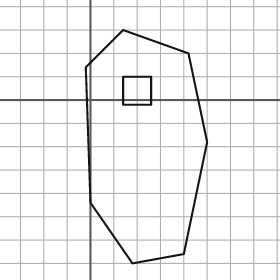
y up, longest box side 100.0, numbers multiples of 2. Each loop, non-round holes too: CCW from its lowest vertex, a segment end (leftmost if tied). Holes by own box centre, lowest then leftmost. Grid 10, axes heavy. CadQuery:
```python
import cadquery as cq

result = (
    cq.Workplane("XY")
    .moveTo(18.0, -70.0)
    .lineTo(40.0, -66.0)
    .lineTo(50.0, -18.0)
    .lineTo(42.0, 20.0)
    .lineTo(14.0, 30.0)
    .lineTo(-2.0, 14.0)
    .lineTo(0.0, -44.0)
    .close()
    .moveTo(14.0, -2.0)
    .lineTo(26.0, -2.0)
    .lineTo(26.0, 10.0)
    .lineTo(14.0, 10.0)
    .close()
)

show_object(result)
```